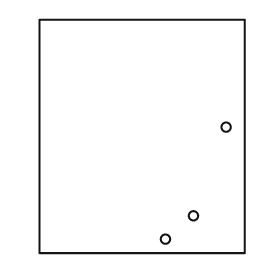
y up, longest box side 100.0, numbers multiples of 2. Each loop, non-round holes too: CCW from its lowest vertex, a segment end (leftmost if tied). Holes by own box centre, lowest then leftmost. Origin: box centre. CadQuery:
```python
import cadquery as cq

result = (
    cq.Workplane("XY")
    .moveTo(-44.0, -50.0)
    .lineTo(44.0, -50.0)
    .lineTo(44.0, 50.0)
    .lineTo(-44.0, 50.0)
    .close()
    .moveTo(10.0, -44.0)
    .circle(2.0)
    .moveTo(22.0, -34.0)
    .circle(2.0)
    .moveTo(36.0, 4.0)
    .circle(2.0)
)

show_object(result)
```